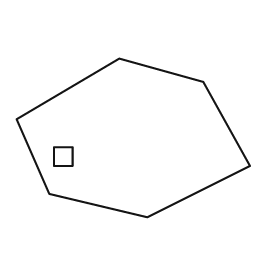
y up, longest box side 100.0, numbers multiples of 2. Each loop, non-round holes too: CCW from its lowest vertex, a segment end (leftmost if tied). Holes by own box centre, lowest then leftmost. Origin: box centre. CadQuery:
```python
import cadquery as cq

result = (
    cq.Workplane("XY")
    .moveTo(6.0, -34.0)
    .lineTo(50.0, -12.0)
    .lineTo(30.0, 24.0)
    .lineTo(-6.0, 34.0)
    .lineTo(-50.0, 8.0)
    .lineTo(-36.0, -24.0)
    .close()
    .moveTo(-34.0, -12.0)
    .lineTo(-26.0, -12.0)
    .lineTo(-26.0, -4.0)
    .lineTo(-34.0, -4.0)
    .close()
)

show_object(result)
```